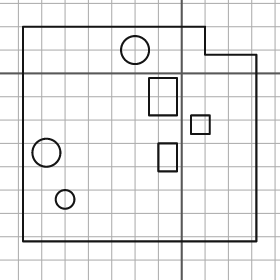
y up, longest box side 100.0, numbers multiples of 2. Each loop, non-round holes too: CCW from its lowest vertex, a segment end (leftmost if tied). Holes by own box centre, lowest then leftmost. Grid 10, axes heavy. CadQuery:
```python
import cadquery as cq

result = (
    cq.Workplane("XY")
    .moveTo(-68.0, -72.0)
    .lineTo(32.0, -72.0)
    .lineTo(32.0, 8.0)
    .lineTo(10.0, 8.0)
    .lineTo(10.0, 20.0)
    .lineTo(-68.0, 20.0)
    .close()
    .moveTo(-50.0, -54.0)
    .circle(4.0)
    .moveTo(-10.0, -42.0)
    .lineTo(-2.0, -42.0)
    .lineTo(-2.0, -30.0)
    .lineTo(-10.0, -30.0)
    .close()
    .moveTo(-58.0, -34.0)
    .circle(6.0)
    .moveTo(4.0, -26.0)
    .lineTo(12.0, -26.0)
    .lineTo(12.0, -18.0)
    .lineTo(4.0, -18.0)
    .close()
    .moveTo(-14.0, -18.0)
    .lineTo(-2.0, -18.0)
    .lineTo(-2.0, -2.0)
    .lineTo(-14.0, -2.0)
    .close()
    .moveTo(-20.0, 10.0)
    .circle(6.0)
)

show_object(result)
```